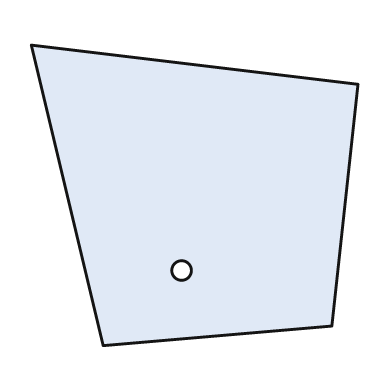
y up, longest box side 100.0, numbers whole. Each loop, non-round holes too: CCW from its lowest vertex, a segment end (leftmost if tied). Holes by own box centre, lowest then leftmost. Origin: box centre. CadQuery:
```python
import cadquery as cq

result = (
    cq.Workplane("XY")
    .moveTo(-28.0, -46.0)
    .lineTo(42.0, -40.0)
    .lineTo(50.0, 34.0)
    .lineTo(-50.0, 46.0)
    .close()
    .moveTo(-4.0, -23.0)
    .circle(3.0)
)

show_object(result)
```